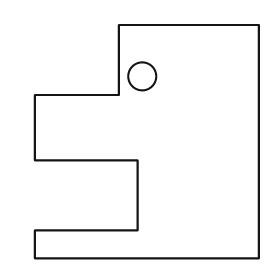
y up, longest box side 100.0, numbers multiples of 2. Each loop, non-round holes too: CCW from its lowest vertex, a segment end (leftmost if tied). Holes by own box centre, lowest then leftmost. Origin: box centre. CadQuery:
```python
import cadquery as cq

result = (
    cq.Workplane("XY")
    .moveTo(-48.0, -50.0)
    .lineTo(48.0, -50.0)
    .lineTo(48.0, 50.0)
    .lineTo(-12.0, 50.0)
    .lineTo(-12.0, 20.0)
    .lineTo(-48.0, 20.0)
    .lineTo(-48.0, -8.0)
    .lineTo(-4.0, -8.0)
    .lineTo(-4.0, -38.0)
    .lineTo(-48.0, -38.0)
    .close()
    .moveTo(-2.0, 28.0)
    .circle(6.0)
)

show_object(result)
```